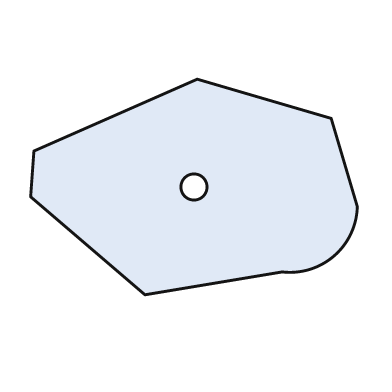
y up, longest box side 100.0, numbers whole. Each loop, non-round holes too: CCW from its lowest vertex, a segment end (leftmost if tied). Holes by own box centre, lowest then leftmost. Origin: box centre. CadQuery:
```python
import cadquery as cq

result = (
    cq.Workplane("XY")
    .moveTo(-15.0, -33.0)
    .lineTo(27.0, -26.0)
    .threePointArc((43.0, -21.0), (50.0, -6.0))
    .lineTo(42.0, 21.0)
    .lineTo(1.0, 33.0)
    .lineTo(-49.0, 11.0)
    .lineTo(-50.0, -3.0)
    .close()
    .moveTo(0.0, 0.0)
    .circle(4.0)
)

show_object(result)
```